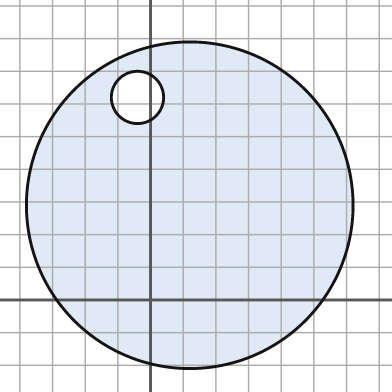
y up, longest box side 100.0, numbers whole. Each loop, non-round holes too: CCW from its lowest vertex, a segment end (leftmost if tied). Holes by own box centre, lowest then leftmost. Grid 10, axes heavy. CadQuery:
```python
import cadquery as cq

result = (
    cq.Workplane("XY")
    .moveTo(12.0, 29.0)
    .circle(50.0)
    .moveTo(-4.0, 62.0)
    .circle(8.0)
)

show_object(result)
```